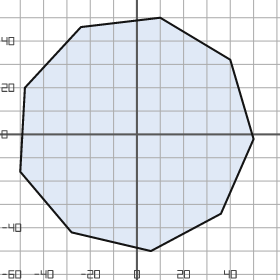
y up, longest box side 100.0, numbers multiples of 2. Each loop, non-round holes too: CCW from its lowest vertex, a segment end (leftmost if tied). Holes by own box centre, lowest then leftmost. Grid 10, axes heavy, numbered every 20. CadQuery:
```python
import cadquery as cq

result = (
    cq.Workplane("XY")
    .moveTo(6.0, -50.0)
    .lineTo(36.0, -34.0)
    .lineTo(50.0, -2.0)
    .lineTo(40.0, 32.0)
    .lineTo(10.0, 50.0)
    .lineTo(-24.0, 46.0)
    .lineTo(-48.0, 20.0)
    .lineTo(-50.0, -16.0)
    .lineTo(-28.0, -42.0)
    .close()
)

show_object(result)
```